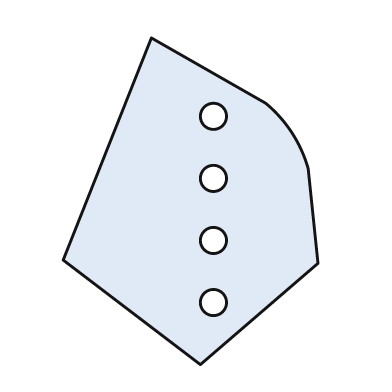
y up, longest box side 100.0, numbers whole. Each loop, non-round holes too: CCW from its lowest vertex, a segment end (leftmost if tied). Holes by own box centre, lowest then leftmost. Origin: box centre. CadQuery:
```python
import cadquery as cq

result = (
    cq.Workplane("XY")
    .moveTo(3.0, -50.0)
    .lineTo(39.0, -19.0)
    .lineTo(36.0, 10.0)
    .threePointArc((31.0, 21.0), (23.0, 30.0))
    .lineTo(-12.0, 50.0)
    .lineTo(-39.0, -18.0)
    .close()
    .moveTo(7.0, -31.0)
    .circle(4.0)
    .moveTo(7.0, -12.0)
    .circle(4.0)
    .moveTo(7.0, 7.0)
    .circle(4.0)
    .moveTo(7.0, 26.0)
    .circle(4.0)
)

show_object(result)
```